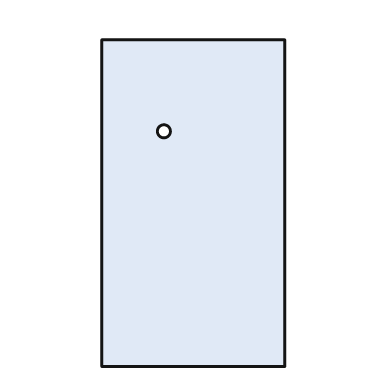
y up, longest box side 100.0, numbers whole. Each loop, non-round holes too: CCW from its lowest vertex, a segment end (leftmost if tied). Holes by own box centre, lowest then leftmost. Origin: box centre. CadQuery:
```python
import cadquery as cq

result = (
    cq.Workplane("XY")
    .moveTo(-28.0, -50.0)
    .lineTo(28.0, -50.0)
    .lineTo(28.0, 50.0)
    .lineTo(-28.0, 50.0)
    .close()
    .moveTo(-9.0, 22.0)
    .circle(2.0)
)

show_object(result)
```